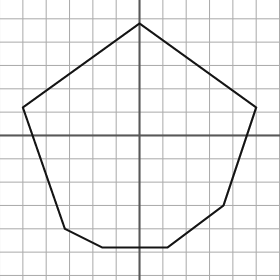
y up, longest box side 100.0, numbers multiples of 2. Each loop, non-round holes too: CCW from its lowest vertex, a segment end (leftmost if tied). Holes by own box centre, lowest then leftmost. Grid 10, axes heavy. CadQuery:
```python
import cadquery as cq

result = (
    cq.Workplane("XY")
    .moveTo(-16.0, -48.0)
    .lineTo(12.0, -48.0)
    .lineTo(36.0, -30.0)
    .lineTo(50.0, 12.0)
    .lineTo(0.0, 48.0)
    .lineTo(-50.0, 12.0)
    .lineTo(-32.0, -40.0)
    .close()
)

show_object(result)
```